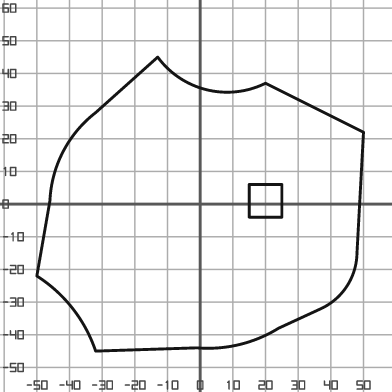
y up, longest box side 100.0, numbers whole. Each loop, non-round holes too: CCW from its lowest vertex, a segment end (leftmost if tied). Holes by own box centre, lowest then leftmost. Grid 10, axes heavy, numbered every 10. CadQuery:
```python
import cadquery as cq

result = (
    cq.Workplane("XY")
    .moveTo(-32.0, -45.0)
    .lineTo(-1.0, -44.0)
    .threePointArc((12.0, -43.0), (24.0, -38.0))
    .lineTo(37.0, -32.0)
    .threePointArc((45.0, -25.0), (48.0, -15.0))
    .lineTo(50.0, 22.0)
    .lineTo(20.0, 37.0)
    .threePointArc((2.0, 35.0), (-13.0, 45.0))
    .lineTo(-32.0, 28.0)
    .threePointArc((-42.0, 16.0), (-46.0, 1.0))
    .lineTo(-50.0, -22.0)
    .threePointArc((-39.0, -32.0), (-32.0, -45.0))
    .close()
    .moveTo(15.0, -4.0)
    .lineTo(25.0, -4.0)
    .lineTo(25.0, 6.0)
    .lineTo(15.0, 6.0)
    .close()
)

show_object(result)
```